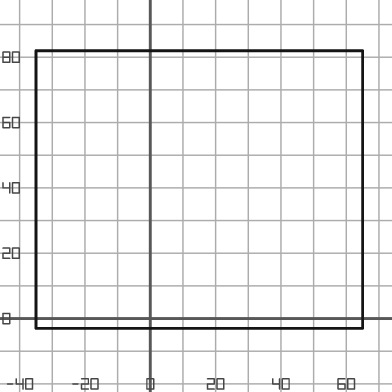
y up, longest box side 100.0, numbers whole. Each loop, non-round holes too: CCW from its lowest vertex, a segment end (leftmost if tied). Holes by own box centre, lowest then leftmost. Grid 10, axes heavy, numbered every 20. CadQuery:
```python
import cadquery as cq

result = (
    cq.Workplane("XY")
    .moveTo(-35.0, -3.0)
    .lineTo(65.0, -3.0)
    .lineTo(65.0, 82.0)
    .lineTo(-35.0, 82.0)
    .close()
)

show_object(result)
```